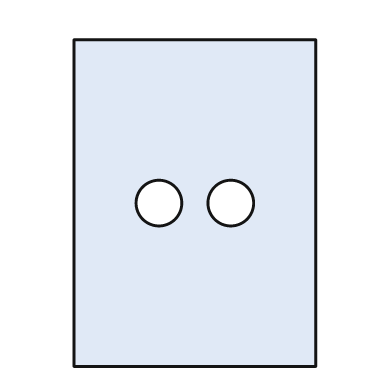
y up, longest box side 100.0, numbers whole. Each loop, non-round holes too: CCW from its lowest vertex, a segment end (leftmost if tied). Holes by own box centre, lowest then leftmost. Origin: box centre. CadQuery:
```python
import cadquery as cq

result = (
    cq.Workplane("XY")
    .moveTo(-37.0, -50.0)
    .lineTo(37.0, -50.0)
    .lineTo(37.0, 50.0)
    .lineTo(-37.0, 50.0)
    .close()
    .moveTo(-11.0, 0.0)
    .circle(7.0)
    .moveTo(11.0, 0.0)
    .circle(7.0)
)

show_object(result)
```